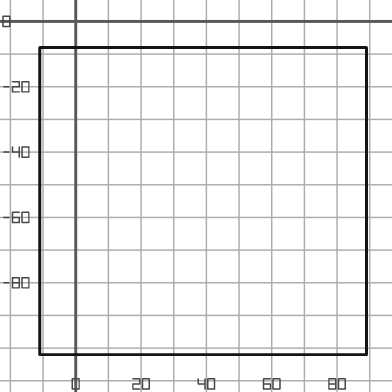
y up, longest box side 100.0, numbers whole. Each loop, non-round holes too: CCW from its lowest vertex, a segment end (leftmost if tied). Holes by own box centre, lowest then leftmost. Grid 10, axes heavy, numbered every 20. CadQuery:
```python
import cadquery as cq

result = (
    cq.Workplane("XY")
    .moveTo(-11.0, -102.0)
    .lineTo(89.0, -102.0)
    .lineTo(89.0, -8.0)
    .lineTo(-11.0, -8.0)
    .close()
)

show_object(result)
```